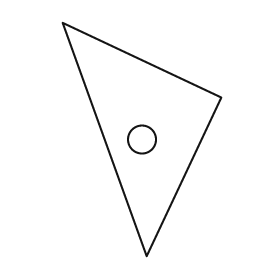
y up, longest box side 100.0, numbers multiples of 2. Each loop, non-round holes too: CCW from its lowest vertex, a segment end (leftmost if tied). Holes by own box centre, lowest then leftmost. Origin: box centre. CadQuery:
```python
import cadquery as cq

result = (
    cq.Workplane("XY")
    .moveTo(2.0, -50.0)
    .lineTo(34.0, 18.0)
    .lineTo(-34.0, 50.0)
    .close()
    .moveTo(0.0, 0.0)
    .circle(6.0)
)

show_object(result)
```